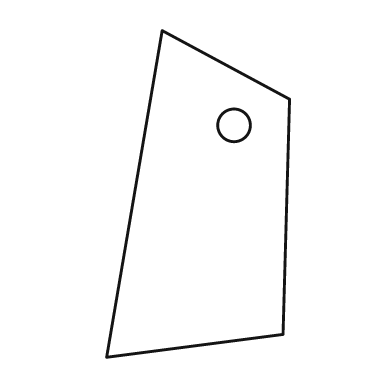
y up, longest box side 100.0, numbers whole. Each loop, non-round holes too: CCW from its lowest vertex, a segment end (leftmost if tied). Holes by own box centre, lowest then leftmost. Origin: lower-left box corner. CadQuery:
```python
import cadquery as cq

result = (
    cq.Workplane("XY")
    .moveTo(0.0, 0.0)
    .lineTo(54.0, 7.0)
    .lineTo(56.0, 79.0)
    .lineTo(17.0, 100.0)
    .close()
    .moveTo(39.0, 71.0)
    .circle(5.0)
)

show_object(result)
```